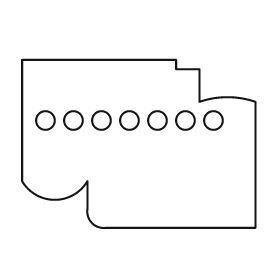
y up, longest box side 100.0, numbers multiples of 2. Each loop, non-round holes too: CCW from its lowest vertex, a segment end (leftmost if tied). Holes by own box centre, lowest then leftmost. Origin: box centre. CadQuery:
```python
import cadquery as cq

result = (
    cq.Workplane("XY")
    .moveTo(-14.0, -36.0)
    .lineTo(50.0, -36.0)
    .lineTo(50.0, 18.0)
    .threePointArc((38.0, 20.0), (26.0, 18.0))
    .lineTo(26.0, 32.0)
    .lineTo(16.0, 32.0)
    .lineTo(16.0, 36.0)
    .lineTo(-50.0, 36.0)
    .lineTo(-50.0, -16.0)
    .threePointArc((-36.0, -24.0), (-22.0, -16.0))
    .lineTo(-22.0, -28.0)
    .threePointArc((-20.0, -34.0), (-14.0, -36.0))
    .close()
    .moveTo(-40.0, 10.0)
    .circle(4.0)
    .moveTo(-28.0, 10.0)
    .circle(4.0)
    .moveTo(-16.0, 10.0)
    .circle(4.0)
    .moveTo(-4.0, 10.0)
    .circle(4.0)
    .moveTo(8.0, 10.0)
    .circle(4.0)
    .moveTo(20.0, 10.0)
    .circle(4.0)
    .moveTo(32.0, 10.0)
    .circle(4.0)
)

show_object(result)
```